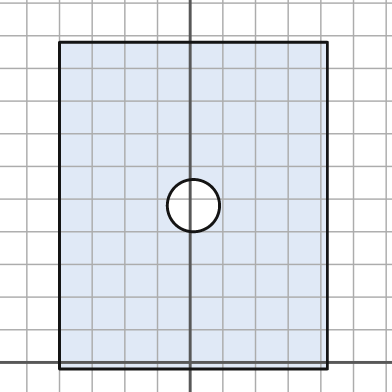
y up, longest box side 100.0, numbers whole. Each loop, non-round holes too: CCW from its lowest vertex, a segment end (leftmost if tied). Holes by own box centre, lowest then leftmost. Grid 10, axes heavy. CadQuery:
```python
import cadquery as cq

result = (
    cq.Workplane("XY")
    .moveTo(-40.0, -2.0)
    .lineTo(42.0, -2.0)
    .lineTo(42.0, 98.0)
    .lineTo(-40.0, 98.0)
    .close()
    .moveTo(1.0, 48.0)
    .circle(8.0)
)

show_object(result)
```